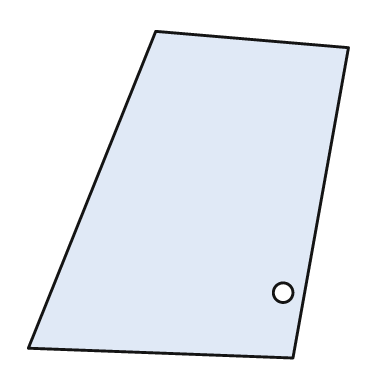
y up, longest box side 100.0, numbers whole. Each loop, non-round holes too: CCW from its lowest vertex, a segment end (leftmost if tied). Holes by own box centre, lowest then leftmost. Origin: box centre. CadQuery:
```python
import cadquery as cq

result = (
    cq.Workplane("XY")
    .moveTo(32.0, -50.0)
    .lineTo(49.0, 45.0)
    .lineTo(-10.0, 50.0)
    .lineTo(-49.0, -47.0)
    .close()
    .moveTo(29.0, -30.0)
    .circle(3.0)
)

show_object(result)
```